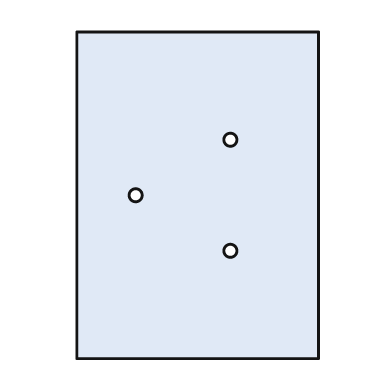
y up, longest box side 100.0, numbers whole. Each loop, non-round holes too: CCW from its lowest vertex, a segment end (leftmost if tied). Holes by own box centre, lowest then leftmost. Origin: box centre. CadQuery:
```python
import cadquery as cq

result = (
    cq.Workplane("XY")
    .moveTo(-37.0, -50.0)
    .lineTo(37.0, -50.0)
    .lineTo(37.0, 50.0)
    .lineTo(-37.0, 50.0)
    .close()
    .moveTo(10.0, -17.0)
    .circle(2.0)
    .moveTo(-19.0, 0.0)
    .circle(2.0)
    .moveTo(10.0, 17.0)
    .circle(2.0)
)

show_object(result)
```